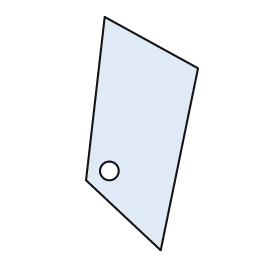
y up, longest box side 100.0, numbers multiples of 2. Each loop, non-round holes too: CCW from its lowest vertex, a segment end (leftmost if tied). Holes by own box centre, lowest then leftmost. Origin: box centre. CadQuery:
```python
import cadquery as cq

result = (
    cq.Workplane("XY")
    .moveTo(8.0, -50.0)
    .lineTo(24.0, 28.0)
    .lineTo(-16.0, 50.0)
    .lineTo(-24.0, -20.0)
    .close()
    .moveTo(-14.0, -16.0)
    .circle(4.0)
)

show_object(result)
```